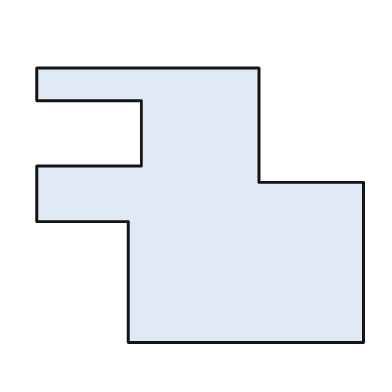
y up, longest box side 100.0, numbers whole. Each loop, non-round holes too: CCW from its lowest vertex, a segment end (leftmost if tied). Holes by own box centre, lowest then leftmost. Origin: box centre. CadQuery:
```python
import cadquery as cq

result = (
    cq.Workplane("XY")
    .moveTo(-22.0, -42.0)
    .lineTo(50.0, -42.0)
    .lineTo(50.0, 7.0)
    .lineTo(18.0, 7.0)
    .lineTo(18.0, 42.0)
    .lineTo(-50.0, 42.0)
    .lineTo(-50.0, 32.0)
    .lineTo(-18.0, 32.0)
    .lineTo(-18.0, 12.0)
    .lineTo(-50.0, 12.0)
    .lineTo(-50.0, -5.0)
    .lineTo(-22.0, -5.0)
    .close()
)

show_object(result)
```